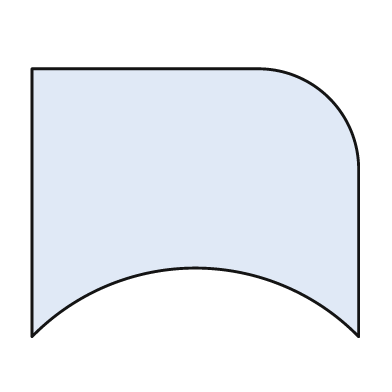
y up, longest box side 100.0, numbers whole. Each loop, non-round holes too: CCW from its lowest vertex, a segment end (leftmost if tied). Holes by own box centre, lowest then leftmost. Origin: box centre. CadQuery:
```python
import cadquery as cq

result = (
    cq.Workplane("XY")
    .moveTo(-50.0, -41.0)
    .threePointArc((0.0, -20.0), (50.0, -41.0))
    .lineTo(50.0, 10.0)
    .threePointArc((41.0, 32.0), (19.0, 41.0))
    .lineTo(-50.0, 41.0)
    .close()
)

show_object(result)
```